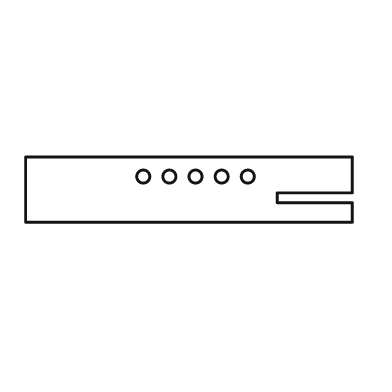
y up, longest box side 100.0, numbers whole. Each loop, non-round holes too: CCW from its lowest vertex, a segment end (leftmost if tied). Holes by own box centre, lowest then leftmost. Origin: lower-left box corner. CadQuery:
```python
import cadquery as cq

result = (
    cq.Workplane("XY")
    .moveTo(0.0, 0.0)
    .lineTo(100.0, 0.0)
    .lineTo(100.0, 6.0)
    .lineTo(77.0, 6.0)
    .lineTo(77.0, 9.0)
    .lineTo(100.0, 9.0)
    .lineTo(100.0, 20.0)
    .lineTo(0.0, 20.0)
    .close()
    .moveTo(36.0, 14.0)
    .circle(2.0)
    .moveTo(44.0, 14.0)
    .circle(2.0)
    .moveTo(52.0, 14.0)
    .circle(2.0)
    .moveTo(60.0, 14.0)
    .circle(2.0)
    .moveTo(68.0, 14.0)
    .circle(2.0)
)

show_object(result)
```